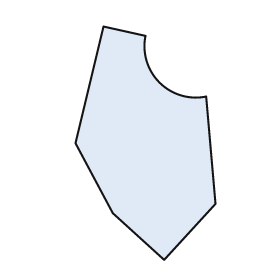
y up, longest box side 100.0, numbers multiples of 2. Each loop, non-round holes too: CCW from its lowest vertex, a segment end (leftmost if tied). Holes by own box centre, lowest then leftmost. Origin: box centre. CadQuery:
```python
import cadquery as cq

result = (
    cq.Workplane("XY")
    .moveTo(8.0, -50.0)
    .lineTo(30.0, -26.0)
    .lineTo(26.0, 20.0)
    .threePointArc((6.0, 26.0), (0.0, 46.0))
    .lineTo(-18.0, 50.0)
    .lineTo(-30.0, 0.0)
    .lineTo(-14.0, -30.0)
    .close()
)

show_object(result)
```